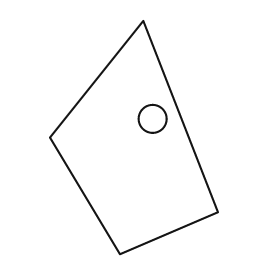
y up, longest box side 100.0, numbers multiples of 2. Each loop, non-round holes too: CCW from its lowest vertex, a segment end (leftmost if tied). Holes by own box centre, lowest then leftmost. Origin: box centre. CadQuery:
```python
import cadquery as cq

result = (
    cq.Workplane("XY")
    .moveTo(-6.0, -50.0)
    .lineTo(36.0, -32.0)
    .lineTo(4.0, 50.0)
    .lineTo(-36.0, 0.0)
    .close()
    .moveTo(8.0, 8.0)
    .circle(6.0)
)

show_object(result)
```